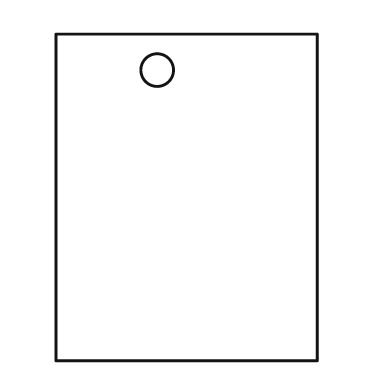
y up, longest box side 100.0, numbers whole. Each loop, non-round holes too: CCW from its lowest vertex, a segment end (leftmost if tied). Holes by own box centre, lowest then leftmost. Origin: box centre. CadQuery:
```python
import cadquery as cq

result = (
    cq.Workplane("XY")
    .moveTo(-40.0, -50.0)
    .lineTo(40.0, -50.0)
    .lineTo(40.0, 50.0)
    .lineTo(-40.0, 50.0)
    .close()
    .moveTo(-9.0, 39.0)
    .circle(5.0)
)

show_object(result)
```